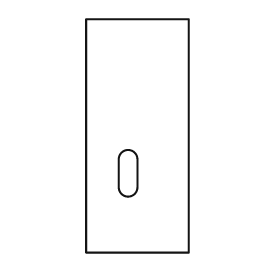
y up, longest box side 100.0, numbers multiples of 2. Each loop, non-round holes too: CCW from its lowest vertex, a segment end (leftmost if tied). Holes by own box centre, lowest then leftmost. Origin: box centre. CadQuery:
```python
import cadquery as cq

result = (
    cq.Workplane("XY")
    .moveTo(-22.0, -50.0)
    .lineTo(22.0, -50.0)
    .lineTo(22.0, 50.0)
    .lineTo(-22.0, 50.0)
    .close()
    .moveTo(-8.0, -22.0)
    .threePointArc((-4.0, -26.0), (0.0, -22.0))
    .lineTo(0.0, -10.0)
    .threePointArc((-4.0, -6.0), (-8.0, -10.0))
    .close()
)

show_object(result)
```